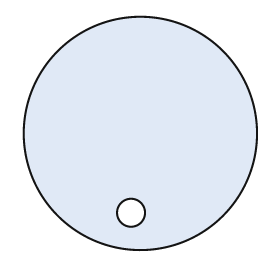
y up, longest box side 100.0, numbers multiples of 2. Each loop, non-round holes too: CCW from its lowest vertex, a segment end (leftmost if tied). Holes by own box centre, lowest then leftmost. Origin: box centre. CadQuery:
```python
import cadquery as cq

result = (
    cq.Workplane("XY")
    .moveTo(0.0, 0.0)
    .circle(50.0)
    .moveTo(-4.0, -34.0)
    .circle(6.0)
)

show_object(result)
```